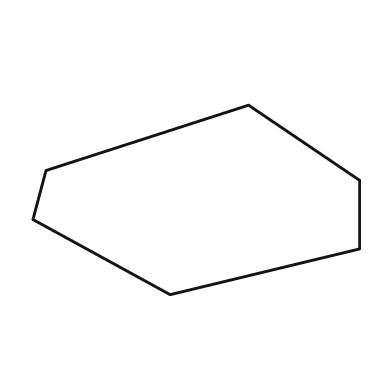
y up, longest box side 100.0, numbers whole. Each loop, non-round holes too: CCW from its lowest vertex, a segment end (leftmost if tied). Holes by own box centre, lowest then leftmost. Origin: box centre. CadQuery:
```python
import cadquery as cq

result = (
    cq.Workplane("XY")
    .moveTo(-8.0, -29.0)
    .lineTo(50.0, -15.0)
    .lineTo(50.0, 6.0)
    .lineTo(16.0, 29.0)
    .lineTo(-46.0, 9.0)
    .lineTo(-50.0, -6.0)
    .close()
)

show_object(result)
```